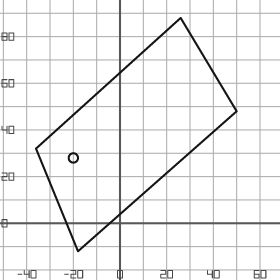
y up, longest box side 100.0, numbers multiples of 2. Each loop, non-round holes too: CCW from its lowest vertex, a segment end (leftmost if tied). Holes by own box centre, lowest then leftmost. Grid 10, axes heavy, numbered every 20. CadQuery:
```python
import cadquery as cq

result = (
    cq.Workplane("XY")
    .moveTo(-18.0, -12.0)
    .lineTo(50.0, 48.0)
    .lineTo(26.0, 88.0)
    .lineTo(-36.0, 32.0)
    .close()
    .moveTo(-20.0, 28.0)
    .circle(2.0)
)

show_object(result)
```